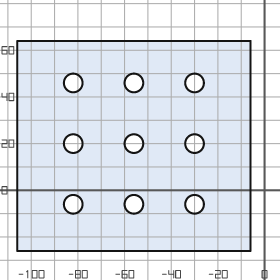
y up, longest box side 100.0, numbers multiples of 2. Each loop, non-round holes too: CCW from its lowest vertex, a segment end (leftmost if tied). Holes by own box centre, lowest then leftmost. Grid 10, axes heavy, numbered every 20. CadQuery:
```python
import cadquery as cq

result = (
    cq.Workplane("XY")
    .moveTo(-106.0, -26.0)
    .lineTo(-6.0, -26.0)
    .lineTo(-6.0, 64.0)
    .lineTo(-106.0, 64.0)
    .close()
    .moveTo(-82.0, -6.0)
    .circle(4.0)
    .moveTo(-56.0, -6.0)
    .circle(4.0)
    .moveTo(-30.0, -6.0)
    .circle(4.0)
    .moveTo(-82.0, 20.0)
    .circle(4.0)
    .moveTo(-56.0, 20.0)
    .circle(4.0)
    .moveTo(-30.0, 20.0)
    .circle(4.0)
    .moveTo(-82.0, 46.0)
    .circle(4.0)
    .moveTo(-56.0, 46.0)
    .circle(4.0)
    .moveTo(-30.0, 46.0)
    .circle(4.0)
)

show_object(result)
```